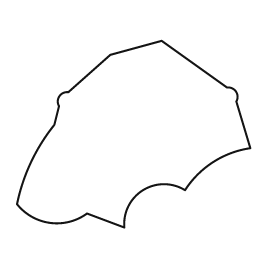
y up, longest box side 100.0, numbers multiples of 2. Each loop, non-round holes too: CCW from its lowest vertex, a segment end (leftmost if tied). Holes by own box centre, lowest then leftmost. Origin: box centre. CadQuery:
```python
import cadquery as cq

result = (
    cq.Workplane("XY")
    .moveTo(-4.0, -40.0)
    .threePointArc((4.0, -24.0), (22.0, -24.0))
    .threePointArc((34.0, -12.0), (50.0, -6.0))
    .lineTo(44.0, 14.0)
    .threePointArc((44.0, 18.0), (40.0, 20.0))
    .lineTo(12.0, 40.0)
    .lineTo(-10.0, 34.0)
    .lineTo(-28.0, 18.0)
    .threePointArc((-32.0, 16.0), (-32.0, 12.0))
    .lineTo(-34.0, 4.0)
    .threePointArc((-44.0, -12.0), (-50.0, -30.0))
    .threePointArc((-36.0, -38.0), (-20.0, -34.0))
    .close()
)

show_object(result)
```